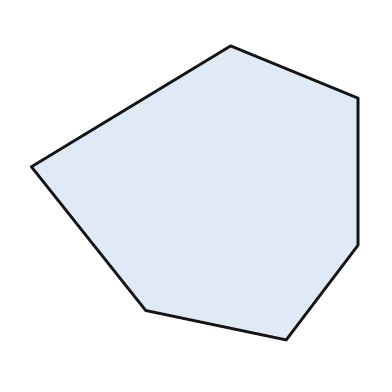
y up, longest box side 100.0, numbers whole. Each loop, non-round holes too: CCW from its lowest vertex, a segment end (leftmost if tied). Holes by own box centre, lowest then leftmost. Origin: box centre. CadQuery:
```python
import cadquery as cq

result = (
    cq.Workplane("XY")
    .moveTo(28.0, -45.0)
    .lineTo(50.0, -16.0)
    .lineTo(50.0, 29.0)
    .lineTo(11.0, 45.0)
    .lineTo(-50.0, 8.0)
    .lineTo(-15.0, -36.0)
    .close()
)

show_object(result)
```